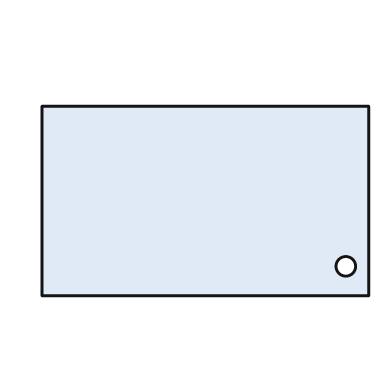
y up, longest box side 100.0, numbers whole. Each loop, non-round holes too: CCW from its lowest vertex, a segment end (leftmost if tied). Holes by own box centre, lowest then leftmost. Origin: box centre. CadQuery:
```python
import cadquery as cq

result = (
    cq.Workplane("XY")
    .moveTo(-50.0, -29.0)
    .lineTo(50.0, -29.0)
    .lineTo(50.0, 29.0)
    .lineTo(-50.0, 29.0)
    .close()
    .moveTo(43.0, -20.0)
    .circle(3.0)
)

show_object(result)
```